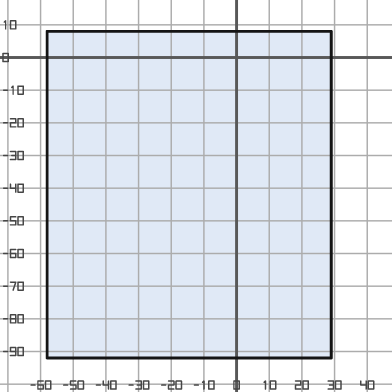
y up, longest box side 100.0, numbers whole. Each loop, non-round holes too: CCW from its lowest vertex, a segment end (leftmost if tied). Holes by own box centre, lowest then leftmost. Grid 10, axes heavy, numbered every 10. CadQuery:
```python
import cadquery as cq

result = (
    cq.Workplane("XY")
    .moveTo(-58.0, -92.0)
    .lineTo(29.0, -92.0)
    .lineTo(29.0, 8.0)
    .lineTo(-58.0, 8.0)
    .close()
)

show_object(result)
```